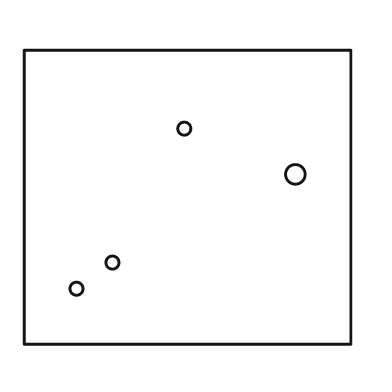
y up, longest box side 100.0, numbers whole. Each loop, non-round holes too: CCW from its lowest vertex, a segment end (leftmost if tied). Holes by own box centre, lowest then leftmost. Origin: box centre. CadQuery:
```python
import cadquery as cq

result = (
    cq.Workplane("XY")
    .moveTo(-50.0, -45.0)
    .lineTo(50.0, -45.0)
    .lineTo(50.0, 45.0)
    .lineTo(-50.0, 45.0)
    .close()
    .moveTo(-34.0, -28.0)
    .circle(2.0)
    .moveTo(-23.0, -20.0)
    .circle(2.0)
    .moveTo(33.0, 7.0)
    .circle(3.0)
    .moveTo(-1.0, 21.0)
    .circle(2.0)
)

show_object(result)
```